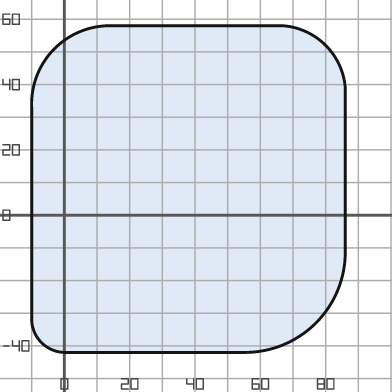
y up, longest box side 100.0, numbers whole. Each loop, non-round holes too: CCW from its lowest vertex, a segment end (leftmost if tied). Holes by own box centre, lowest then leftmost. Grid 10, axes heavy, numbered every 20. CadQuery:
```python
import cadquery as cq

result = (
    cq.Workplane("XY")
    .moveTo(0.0, -42.0)
    .lineTo(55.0, -42.0)
    .threePointArc((77.0, -33.0), (86.0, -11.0))
    .lineTo(86.0, 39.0)
    .threePointArc((80.0, 52.0), (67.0, 58.0))
    .lineTo(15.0, 58.0)
    .threePointArc((-3.0, 51.0), (-10.0, 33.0))
    .lineTo(-10.0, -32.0)
    .threePointArc((-7.0, -39.0), (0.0, -42.0))
    .close()
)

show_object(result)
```